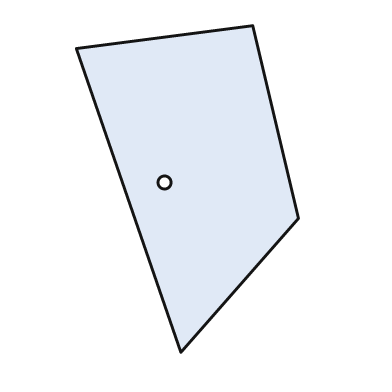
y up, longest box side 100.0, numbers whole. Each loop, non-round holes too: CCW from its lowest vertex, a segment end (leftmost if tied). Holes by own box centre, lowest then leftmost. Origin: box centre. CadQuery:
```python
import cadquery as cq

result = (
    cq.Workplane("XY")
    .moveTo(-2.0, -50.0)
    .lineTo(34.0, -9.0)
    .lineTo(20.0, 50.0)
    .lineTo(-34.0, 43.0)
    .close()
    .moveTo(-7.0, 2.0)
    .circle(2.0)
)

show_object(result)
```